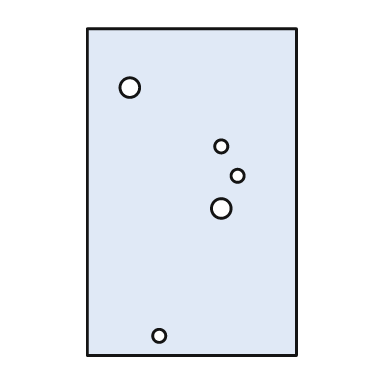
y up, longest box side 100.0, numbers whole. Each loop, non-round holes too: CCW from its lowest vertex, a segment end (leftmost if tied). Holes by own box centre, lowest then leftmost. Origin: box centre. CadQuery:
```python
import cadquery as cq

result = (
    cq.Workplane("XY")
    .moveTo(-32.0, -50.0)
    .lineTo(32.0, -50.0)
    .lineTo(32.0, 50.0)
    .lineTo(-32.0, 50.0)
    .close()
    .moveTo(-10.0, -44.0)
    .circle(2.0)
    .moveTo(9.0, -5.0)
    .circle(3.0)
    .moveTo(14.0, 5.0)
    .circle(2.0)
    .moveTo(9.0, 14.0)
    .circle(2.0)
    .moveTo(-19.0, 32.0)
    .circle(3.0)
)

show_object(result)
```